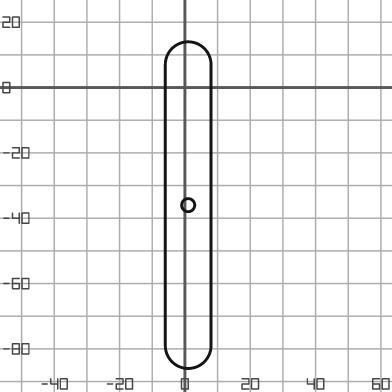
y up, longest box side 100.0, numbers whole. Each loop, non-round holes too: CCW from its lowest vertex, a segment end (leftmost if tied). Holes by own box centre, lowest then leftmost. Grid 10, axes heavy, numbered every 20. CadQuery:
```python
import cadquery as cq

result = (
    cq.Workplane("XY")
    .moveTo(-6.0, -79.0)
    .threePointArc((1.0, -86.0), (8.0, -79.0))
    .lineTo(8.0, 7.0)
    .threePointArc((1.0, 14.0), (-6.0, 7.0))
    .close()
    .moveTo(1.0, -36.0)
    .circle(2.0)
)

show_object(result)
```